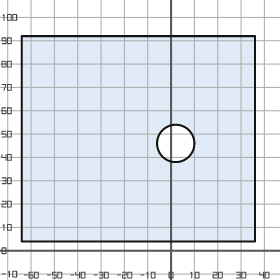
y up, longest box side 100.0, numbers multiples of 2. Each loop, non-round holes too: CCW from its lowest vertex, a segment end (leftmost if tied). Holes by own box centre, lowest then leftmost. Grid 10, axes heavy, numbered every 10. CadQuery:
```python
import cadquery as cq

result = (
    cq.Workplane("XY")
    .moveTo(-64.0, 4.0)
    .lineTo(36.0, 4.0)
    .lineTo(36.0, 92.0)
    .lineTo(-64.0, 92.0)
    .close()
    .moveTo(2.0, 46.0)
    .circle(8.0)
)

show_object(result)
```